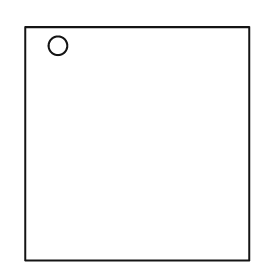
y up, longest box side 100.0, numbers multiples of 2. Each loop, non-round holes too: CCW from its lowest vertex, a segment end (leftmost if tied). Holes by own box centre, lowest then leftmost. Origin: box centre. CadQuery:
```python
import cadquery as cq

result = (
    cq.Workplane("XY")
    .moveTo(-48.0, -50.0)
    .lineTo(48.0, -50.0)
    .lineTo(48.0, 50.0)
    .lineTo(-48.0, 50.0)
    .close()
    .moveTo(-34.0, 42.0)
    .circle(4.0)
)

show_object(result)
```